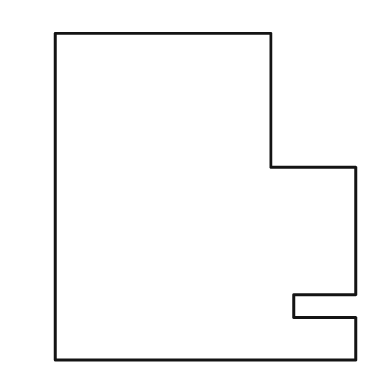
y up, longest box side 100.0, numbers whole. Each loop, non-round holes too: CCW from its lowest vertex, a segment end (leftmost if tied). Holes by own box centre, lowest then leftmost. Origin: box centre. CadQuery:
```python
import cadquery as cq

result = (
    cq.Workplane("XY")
    .moveTo(-46.0, -50.0)
    .lineTo(46.0, -50.0)
    .lineTo(46.0, -37.0)
    .lineTo(27.0, -37.0)
    .lineTo(27.0, -30.0)
    .lineTo(46.0, -30.0)
    .lineTo(46.0, 9.0)
    .lineTo(20.0, 9.0)
    .lineTo(20.0, 50.0)
    .lineTo(-46.0, 50.0)
    .close()
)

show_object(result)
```